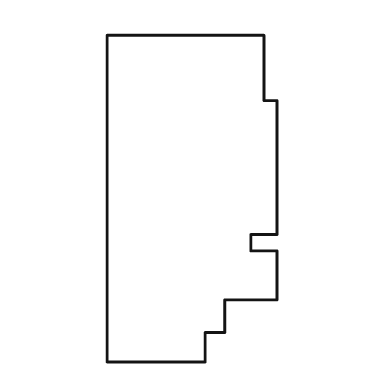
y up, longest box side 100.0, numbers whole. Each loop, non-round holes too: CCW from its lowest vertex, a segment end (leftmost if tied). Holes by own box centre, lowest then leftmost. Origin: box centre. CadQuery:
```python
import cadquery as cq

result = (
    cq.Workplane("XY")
    .moveTo(-26.0, -50.0)
    .lineTo(4.0, -50.0)
    .lineTo(4.0, -41.0)
    .lineTo(10.0, -41.0)
    .lineTo(10.0, -31.0)
    .lineTo(26.0, -31.0)
    .lineTo(26.0, -16.0)
    .lineTo(18.0, -16.0)
    .lineTo(18.0, -11.0)
    .lineTo(26.0, -11.0)
    .lineTo(26.0, 30.0)
    .lineTo(22.0, 30.0)
    .lineTo(22.0, 50.0)
    .lineTo(-26.0, 50.0)
    .close()
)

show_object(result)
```